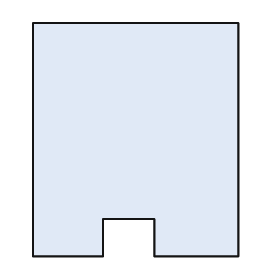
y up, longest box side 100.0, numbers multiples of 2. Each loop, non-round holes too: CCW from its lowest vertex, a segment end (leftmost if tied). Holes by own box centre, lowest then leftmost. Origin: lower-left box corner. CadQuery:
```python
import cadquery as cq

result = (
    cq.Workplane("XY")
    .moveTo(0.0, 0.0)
    .lineTo(30.0, 0.0)
    .lineTo(30.0, 16.0)
    .lineTo(52.0, 16.0)
    .lineTo(52.0, 0.0)
    .lineTo(88.0, 0.0)
    .lineTo(88.0, 100.0)
    .lineTo(0.0, 100.0)
    .close()
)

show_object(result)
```